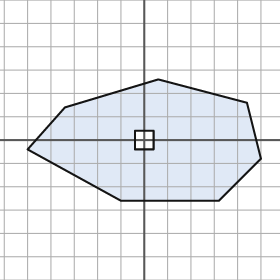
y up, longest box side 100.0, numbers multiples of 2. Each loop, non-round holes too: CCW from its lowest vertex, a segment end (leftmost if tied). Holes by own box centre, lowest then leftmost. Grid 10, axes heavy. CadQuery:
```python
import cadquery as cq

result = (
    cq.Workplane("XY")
    .moveTo(-10.0, -26.0)
    .lineTo(32.0, -26.0)
    .lineTo(50.0, -8.0)
    .lineTo(44.0, 16.0)
    .lineTo(6.0, 26.0)
    .lineTo(-34.0, 14.0)
    .lineTo(-50.0, -4.0)
    .close()
    .moveTo(-4.0, -4.0)
    .lineTo(4.0, -4.0)
    .lineTo(4.0, 4.0)
    .lineTo(-4.0, 4.0)
    .close()
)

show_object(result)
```